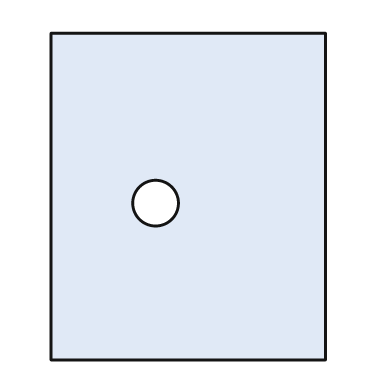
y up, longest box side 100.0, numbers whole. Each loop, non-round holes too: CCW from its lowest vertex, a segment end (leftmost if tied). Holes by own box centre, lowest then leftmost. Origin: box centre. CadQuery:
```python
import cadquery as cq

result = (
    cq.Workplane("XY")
    .moveTo(-42.0, -50.0)
    .lineTo(42.0, -50.0)
    .lineTo(42.0, 50.0)
    .lineTo(-42.0, 50.0)
    .close()
    .moveTo(-10.0, -2.0)
    .circle(7.0)
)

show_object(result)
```